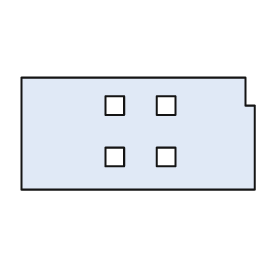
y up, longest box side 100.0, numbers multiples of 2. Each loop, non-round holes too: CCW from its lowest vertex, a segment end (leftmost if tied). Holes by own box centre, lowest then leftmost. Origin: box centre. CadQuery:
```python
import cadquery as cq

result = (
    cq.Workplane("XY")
    .moveTo(-50.0, -24.0)
    .lineTo(50.0, -24.0)
    .lineTo(50.0, 12.0)
    .lineTo(46.0, 12.0)
    .lineTo(46.0, 24.0)
    .lineTo(-50.0, 24.0)
    .close()
    .moveTo(-14.0, -14.0)
    .lineTo(-6.0, -14.0)
    .lineTo(-6.0, -6.0)
    .lineTo(-14.0, -6.0)
    .close()
    .moveTo(8.0, -14.0)
    .lineTo(16.0, -14.0)
    .lineTo(16.0, -6.0)
    .lineTo(8.0, -6.0)
    .close()
    .moveTo(-14.0, 8.0)
    .lineTo(-6.0, 8.0)
    .lineTo(-6.0, 16.0)
    .lineTo(-14.0, 16.0)
    .close()
    .moveTo(8.0, 8.0)
    .lineTo(16.0, 8.0)
    .lineTo(16.0, 16.0)
    .lineTo(8.0, 16.0)
    .close()
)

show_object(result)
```